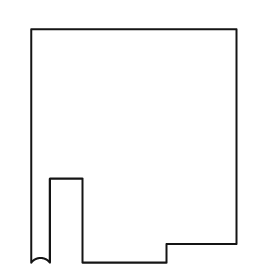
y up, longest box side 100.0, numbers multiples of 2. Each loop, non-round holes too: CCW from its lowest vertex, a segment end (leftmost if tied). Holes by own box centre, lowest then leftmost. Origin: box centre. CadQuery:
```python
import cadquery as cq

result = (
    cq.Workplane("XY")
    .moveTo(-44.0, -50.0)
    .threePointArc((-40.0, -48.0), (-36.0, -50.0))
    .lineTo(-36.0, -14.0)
    .lineTo(-22.0, -14.0)
    .lineTo(-22.0, -50.0)
    .lineTo(14.0, -50.0)
    .lineTo(14.0, -42.0)
    .lineTo(44.0, -42.0)
    .lineTo(44.0, 50.0)
    .lineTo(-44.0, 50.0)
    .close()
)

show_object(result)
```